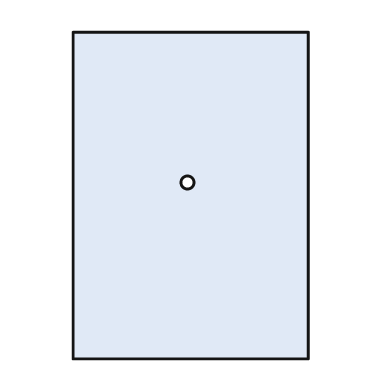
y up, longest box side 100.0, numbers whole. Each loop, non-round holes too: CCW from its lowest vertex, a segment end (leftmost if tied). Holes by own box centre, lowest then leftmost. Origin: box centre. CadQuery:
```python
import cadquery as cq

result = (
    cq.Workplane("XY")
    .moveTo(-36.0, -50.0)
    .lineTo(36.0, -50.0)
    .lineTo(36.0, 50.0)
    .lineTo(-36.0, 50.0)
    .close()
    .moveTo(-1.0, 4.0)
    .circle(2.0)
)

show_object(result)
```